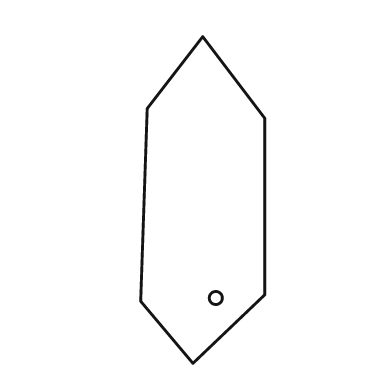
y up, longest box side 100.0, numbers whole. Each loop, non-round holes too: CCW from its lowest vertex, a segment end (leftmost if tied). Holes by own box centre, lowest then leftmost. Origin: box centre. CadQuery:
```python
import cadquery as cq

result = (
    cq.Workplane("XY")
    .moveTo(-3.0, -50.0)
    .lineTo(19.0, -29.0)
    .lineTo(19.0, 25.0)
    .lineTo(0.0, 50.0)
    .lineTo(-17.0, 28.0)
    .lineTo(-19.0, -31.0)
    .close()
    .moveTo(4.0, -30.0)
    .circle(2.0)
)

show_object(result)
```